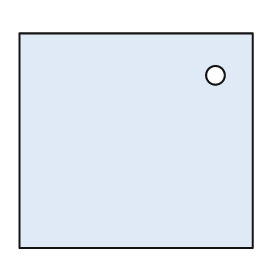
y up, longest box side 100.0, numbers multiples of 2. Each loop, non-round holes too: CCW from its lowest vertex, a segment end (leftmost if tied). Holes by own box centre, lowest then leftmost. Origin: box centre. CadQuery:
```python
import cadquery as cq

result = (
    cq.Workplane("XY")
    .moveTo(-50.0, -46.0)
    .lineTo(50.0, -46.0)
    .lineTo(50.0, 46.0)
    .lineTo(-50.0, 46.0)
    .close()
    .moveTo(34.0, 28.0)
    .circle(4.0)
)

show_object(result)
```